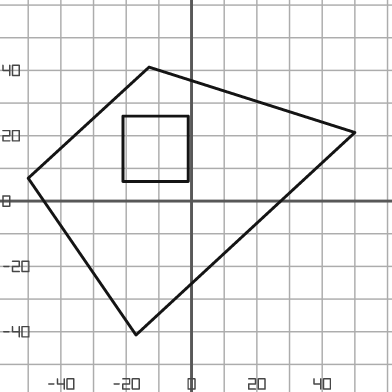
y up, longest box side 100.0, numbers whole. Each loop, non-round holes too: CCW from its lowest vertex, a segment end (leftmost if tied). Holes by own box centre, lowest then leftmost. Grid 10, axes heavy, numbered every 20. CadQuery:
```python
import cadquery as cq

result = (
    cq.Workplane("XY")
    .moveTo(-17.0, -41.0)
    .lineTo(50.0, 21.0)
    .lineTo(-13.0, 41.0)
    .lineTo(-50.0, 7.0)
    .close()
    .moveTo(-21.0, 6.0)
    .lineTo(-1.0, 6.0)
    .lineTo(-1.0, 26.0)
    .lineTo(-21.0, 26.0)
    .close()
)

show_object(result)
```